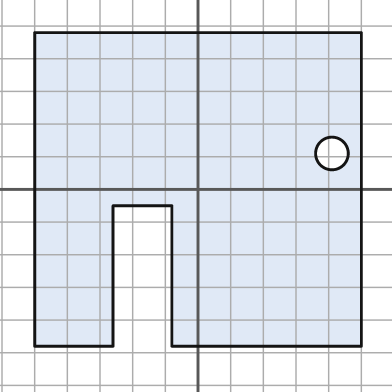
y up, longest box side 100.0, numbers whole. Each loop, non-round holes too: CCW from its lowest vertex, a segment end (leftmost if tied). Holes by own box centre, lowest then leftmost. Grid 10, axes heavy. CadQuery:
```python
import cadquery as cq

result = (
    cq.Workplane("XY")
    .moveTo(-50.0, -48.0)
    .lineTo(-26.0, -48.0)
    .lineTo(-26.0, -5.0)
    .lineTo(-8.0, -5.0)
    .lineTo(-8.0, -48.0)
    .lineTo(50.0, -48.0)
    .lineTo(50.0, 48.0)
    .lineTo(-50.0, 48.0)
    .close()
    .moveTo(41.0, 11.0)
    .circle(5.0)
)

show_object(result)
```